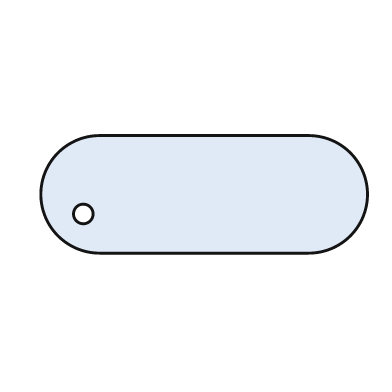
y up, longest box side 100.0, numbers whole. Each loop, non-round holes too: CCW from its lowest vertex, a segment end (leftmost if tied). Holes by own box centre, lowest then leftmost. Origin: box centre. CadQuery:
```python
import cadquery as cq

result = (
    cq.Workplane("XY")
    .moveTo(-32.0, -18.0)
    .lineTo(32.0, -18.0)
    .threePointArc((50.0, 0.0), (32.0, 18.0))
    .lineTo(-32.0, 18.0)
    .threePointArc((-50.0, 0.0), (-32.0, -18.0))
    .close()
    .moveTo(-37.0, -6.0)
    .circle(3.0)
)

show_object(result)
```